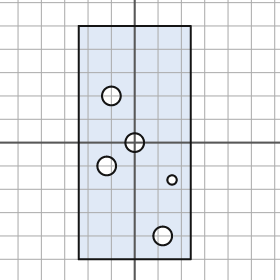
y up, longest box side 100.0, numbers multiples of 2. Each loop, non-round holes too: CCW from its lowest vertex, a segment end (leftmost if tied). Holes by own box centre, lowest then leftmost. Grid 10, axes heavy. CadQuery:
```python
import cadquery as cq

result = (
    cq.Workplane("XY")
    .moveTo(-24.0, -50.0)
    .lineTo(24.0, -50.0)
    .lineTo(24.0, 50.0)
    .lineTo(-24.0, 50.0)
    .close()
    .moveTo(12.0, -40.0)
    .circle(4.0)
    .moveTo(16.0, -16.0)
    .circle(2.0)
    .moveTo(-12.0, -10.0)
    .circle(4.0)
    .moveTo(0.0, 0.0)
    .circle(4.0)
    .moveTo(-10.0, 20.0)
    .circle(4.0)
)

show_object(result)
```